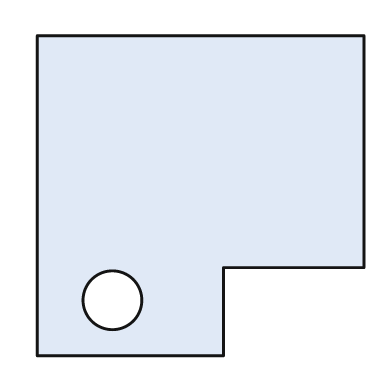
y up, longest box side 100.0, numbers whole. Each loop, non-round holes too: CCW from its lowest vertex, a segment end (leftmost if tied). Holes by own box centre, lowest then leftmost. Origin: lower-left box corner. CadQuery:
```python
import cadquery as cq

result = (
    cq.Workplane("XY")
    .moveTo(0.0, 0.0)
    .lineTo(57.0, 0.0)
    .lineTo(57.0, 27.0)
    .lineTo(100.0, 27.0)
    .lineTo(100.0, 98.0)
    .lineTo(0.0, 98.0)
    .close()
    .moveTo(23.0, 17.0)
    .circle(9.0)
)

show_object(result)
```